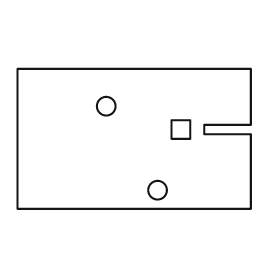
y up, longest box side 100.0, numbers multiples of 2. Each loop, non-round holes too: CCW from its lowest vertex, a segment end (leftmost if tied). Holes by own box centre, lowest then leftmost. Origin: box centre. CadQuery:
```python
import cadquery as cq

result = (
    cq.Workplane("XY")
    .moveTo(-50.0, -30.0)
    .lineTo(50.0, -30.0)
    .lineTo(50.0, 2.0)
    .lineTo(30.0, 2.0)
    .lineTo(30.0, 6.0)
    .lineTo(50.0, 6.0)
    .lineTo(50.0, 30.0)
    .lineTo(-50.0, 30.0)
    .close()
    .moveTo(10.0, -22.0)
    .circle(4.0)
    .moveTo(16.0, 0.0)
    .lineTo(24.0, 0.0)
    .lineTo(24.0, 8.0)
    .lineTo(16.0, 8.0)
    .close()
    .moveTo(-12.0, 14.0)
    .circle(4.0)
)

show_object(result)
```